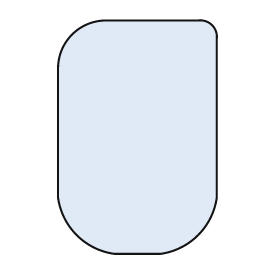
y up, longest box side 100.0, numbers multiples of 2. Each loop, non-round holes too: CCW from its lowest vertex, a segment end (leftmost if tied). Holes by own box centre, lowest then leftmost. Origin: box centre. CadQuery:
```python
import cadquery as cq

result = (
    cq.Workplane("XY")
    .moveTo(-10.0, -50.0)
    .lineTo(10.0, -50.0)
    .threePointArc((26.0, -42.0), (34.0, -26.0))
    .lineTo(34.0, 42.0)
    .threePointArc((32.0, 48.0), (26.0, 50.0))
    .lineTo(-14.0, 50.0)
    .threePointArc((-28.0, 44.0), (-34.0, 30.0))
    .lineTo(-34.0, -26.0)
    .threePointArc((-26.0, -42.0), (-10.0, -50.0))
    .close()
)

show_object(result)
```